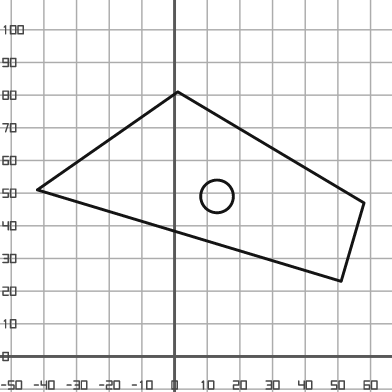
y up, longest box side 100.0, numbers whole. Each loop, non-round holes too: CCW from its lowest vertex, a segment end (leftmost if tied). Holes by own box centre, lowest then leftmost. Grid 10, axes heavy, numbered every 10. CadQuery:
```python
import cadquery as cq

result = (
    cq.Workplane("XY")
    .moveTo(51.0, 23.0)
    .lineTo(58.0, 47.0)
    .lineTo(1.0, 81.0)
    .lineTo(-42.0, 51.0)
    .close()
    .moveTo(13.0, 49.0)
    .circle(5.0)
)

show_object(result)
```